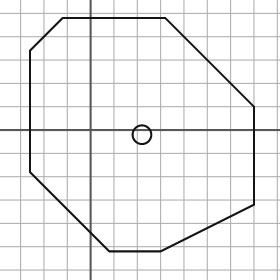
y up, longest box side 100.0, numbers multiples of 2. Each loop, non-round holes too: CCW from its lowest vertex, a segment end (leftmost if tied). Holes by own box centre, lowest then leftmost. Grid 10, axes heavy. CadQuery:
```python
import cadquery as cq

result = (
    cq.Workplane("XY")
    .moveTo(8.0, -52.0)
    .lineTo(30.0, -52.0)
    .lineTo(70.0, -32.0)
    .lineTo(70.0, 10.0)
    .lineTo(32.0, 48.0)
    .lineTo(-12.0, 48.0)
    .lineTo(-26.0, 34.0)
    .lineTo(-26.0, -18.0)
    .close()
    .moveTo(22.0, -2.0)
    .circle(4.0)
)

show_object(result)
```